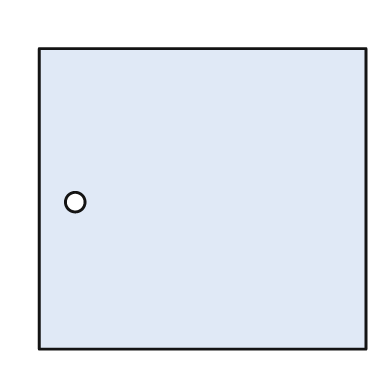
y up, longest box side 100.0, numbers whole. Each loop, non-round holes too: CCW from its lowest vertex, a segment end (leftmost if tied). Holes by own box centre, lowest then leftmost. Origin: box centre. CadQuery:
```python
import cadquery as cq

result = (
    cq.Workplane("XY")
    .moveTo(-50.0, -46.0)
    .lineTo(50.0, -46.0)
    .lineTo(50.0, 46.0)
    .lineTo(-50.0, 46.0)
    .close()
    .moveTo(-39.0, -1.0)
    .circle(3.0)
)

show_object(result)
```